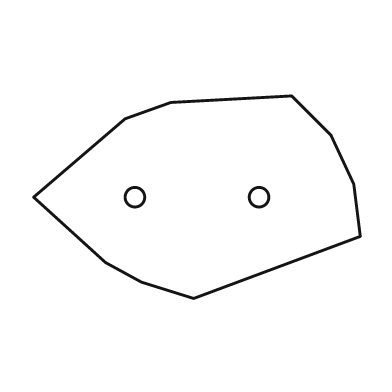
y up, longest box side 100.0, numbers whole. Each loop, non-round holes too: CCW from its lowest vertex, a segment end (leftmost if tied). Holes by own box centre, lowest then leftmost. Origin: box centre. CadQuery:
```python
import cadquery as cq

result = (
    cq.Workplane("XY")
    .moveTo(-1.0, -31.0)
    .lineTo(50.0, -12.0)
    .lineTo(48.0, 4.0)
    .lineTo(41.0, 19.0)
    .lineTo(29.0, 31.0)
    .lineTo(-8.0, 29.0)
    .lineTo(-22.0, 24.0)
    .lineTo(-50.0, 0.0)
    .lineTo(-28.0, -20.0)
    .lineTo(-17.0, -26.0)
    .close()
    .moveTo(-19.0, 0.0)
    .circle(3.0)
    .moveTo(19.0, 0.0)
    .circle(3.0)
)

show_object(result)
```